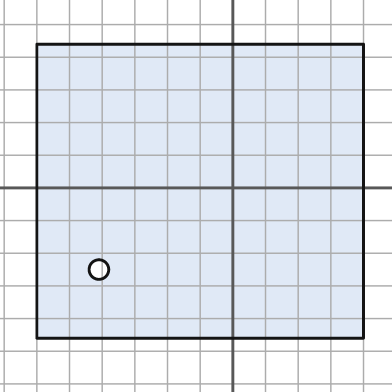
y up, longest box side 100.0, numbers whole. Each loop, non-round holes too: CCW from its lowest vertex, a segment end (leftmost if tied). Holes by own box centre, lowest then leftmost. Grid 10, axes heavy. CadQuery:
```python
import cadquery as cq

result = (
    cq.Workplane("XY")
    .moveTo(-60.0, -46.0)
    .lineTo(40.0, -46.0)
    .lineTo(40.0, 44.0)
    .lineTo(-60.0, 44.0)
    .close()
    .moveTo(-41.0, -25.0)
    .circle(3.0)
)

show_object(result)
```